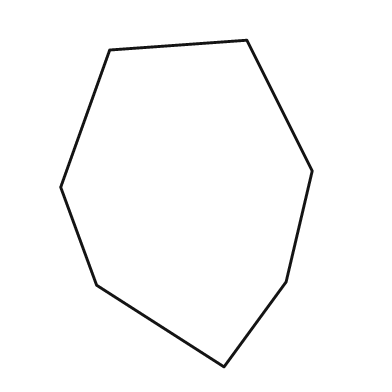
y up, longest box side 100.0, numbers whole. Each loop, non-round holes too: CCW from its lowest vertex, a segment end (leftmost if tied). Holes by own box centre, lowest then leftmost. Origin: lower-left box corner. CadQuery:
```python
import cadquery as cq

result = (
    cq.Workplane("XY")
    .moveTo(50.0, 0.0)
    .lineTo(69.0, 26.0)
    .lineTo(77.0, 60.0)
    .lineTo(57.0, 100.0)
    .lineTo(15.0, 97.0)
    .lineTo(0.0, 55.0)
    .lineTo(11.0, 25.0)
    .close()
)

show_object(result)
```